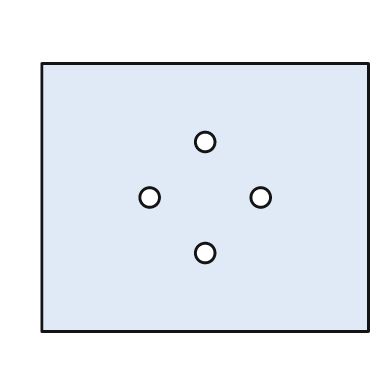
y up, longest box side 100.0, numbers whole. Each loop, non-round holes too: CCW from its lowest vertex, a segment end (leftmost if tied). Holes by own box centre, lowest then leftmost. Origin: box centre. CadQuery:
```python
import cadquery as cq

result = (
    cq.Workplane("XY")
    .moveTo(-50.0, -41.0)
    .lineTo(50.0, -41.0)
    .lineTo(50.0, 41.0)
    .lineTo(-50.0, 41.0)
    .close()
    .moveTo(0.0, -17.0)
    .circle(3.0)
    .moveTo(-17.0, 0.0)
    .circle(3.0)
    .moveTo(17.0, 0.0)
    .circle(3.0)
    .moveTo(0.0, 17.0)
    .circle(3.0)
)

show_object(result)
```